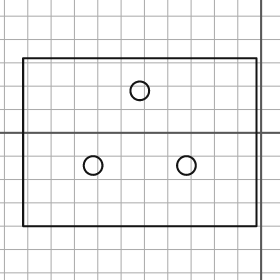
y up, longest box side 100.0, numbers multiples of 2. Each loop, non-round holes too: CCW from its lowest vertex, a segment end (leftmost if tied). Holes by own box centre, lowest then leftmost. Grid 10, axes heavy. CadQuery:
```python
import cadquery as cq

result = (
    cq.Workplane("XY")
    .moveTo(-102.0, -40.0)
    .lineTo(-2.0, -40.0)
    .lineTo(-2.0, 32.0)
    .lineTo(-102.0, 32.0)
    .close()
    .moveTo(-72.0, -14.0)
    .circle(4.0)
    .moveTo(-32.0, -14.0)
    .circle(4.0)
    .moveTo(-52.0, 18.0)
    .circle(4.0)
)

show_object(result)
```